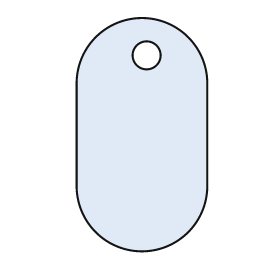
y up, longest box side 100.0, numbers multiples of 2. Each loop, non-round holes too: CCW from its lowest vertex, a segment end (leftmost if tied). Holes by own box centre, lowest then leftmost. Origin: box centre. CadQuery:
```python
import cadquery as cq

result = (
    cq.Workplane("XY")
    .moveTo(-28.0, -22.0)
    .threePointArc((0.0, -50.0), (28.0, -22.0))
    .lineTo(28.0, 22.0)
    .threePointArc((0.0, 50.0), (-28.0, 22.0))
    .close()
    .moveTo(2.0, 34.0)
    .circle(6.0)
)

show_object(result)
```